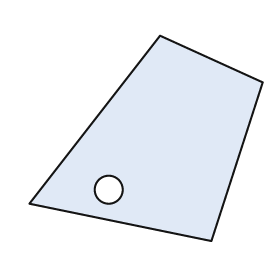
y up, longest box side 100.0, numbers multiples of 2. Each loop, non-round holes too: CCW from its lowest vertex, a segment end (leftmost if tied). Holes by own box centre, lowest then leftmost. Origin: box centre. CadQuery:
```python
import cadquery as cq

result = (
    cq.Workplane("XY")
    .moveTo(28.0, -44.0)
    .lineTo(50.0, 24.0)
    .lineTo(6.0, 44.0)
    .lineTo(-50.0, -28.0)
    .close()
    .moveTo(-16.0, -22.0)
    .circle(6.0)
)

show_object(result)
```